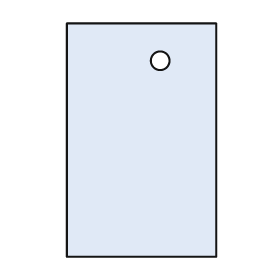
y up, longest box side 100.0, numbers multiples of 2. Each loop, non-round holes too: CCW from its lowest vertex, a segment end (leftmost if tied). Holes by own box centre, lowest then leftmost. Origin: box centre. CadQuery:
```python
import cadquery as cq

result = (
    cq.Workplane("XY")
    .moveTo(-32.0, -50.0)
    .lineTo(32.0, -50.0)
    .lineTo(32.0, 50.0)
    .lineTo(-32.0, 50.0)
    .close()
    .moveTo(8.0, 34.0)
    .circle(4.0)
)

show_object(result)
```